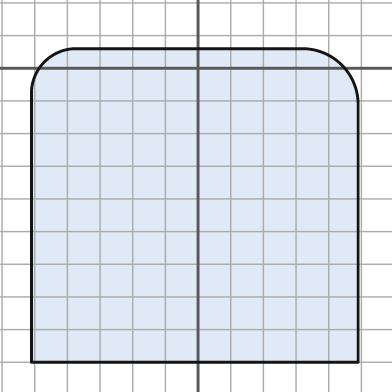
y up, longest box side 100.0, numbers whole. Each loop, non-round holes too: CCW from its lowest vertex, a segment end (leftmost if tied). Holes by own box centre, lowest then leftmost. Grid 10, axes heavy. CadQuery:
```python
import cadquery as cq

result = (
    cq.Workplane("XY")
    .moveTo(-51.0, -90.0)
    .lineTo(49.0, -90.0)
    .lineTo(49.0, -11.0)
    .threePointArc((44.0, 1.0), (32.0, 6.0))
    .lineTo(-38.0, 6.0)
    .threePointArc((-47.0, 2.0), (-51.0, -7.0))
    .close()
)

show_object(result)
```